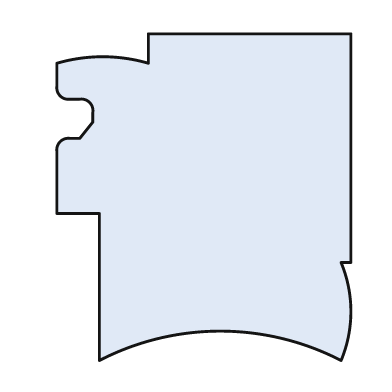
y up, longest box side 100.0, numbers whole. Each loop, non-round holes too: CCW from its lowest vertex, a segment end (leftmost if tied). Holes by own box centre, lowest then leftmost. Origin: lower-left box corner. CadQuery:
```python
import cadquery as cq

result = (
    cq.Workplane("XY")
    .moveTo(13.0, 0.0)
    .threePointArc((50.0, 9.0), (87.0, 0.0))
    .threePointArc((90.0, 15.0), (87.0, 30.0))
    .lineTo(90.0, 30.0)
    .lineTo(90.0, 100.0)
    .lineTo(28.0, 100.0)
    .lineTo(28.0, 91.0)
    .threePointArc((14.0, 93.0), (0.0, 91.0))
    .lineTo(0.0, 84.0)
    .threePointArc((1.0, 81.0), (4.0, 80.0))
    .lineTo(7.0, 80.0)
    .threePointArc((10.0, 79.0), (11.0, 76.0))
    .lineTo(11.0, 73.0)
    .lineTo(7.0, 68.0)
    .lineTo(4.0, 68.0)
    .threePointArc((1.0, 67.0), (0.0, 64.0))
    .lineTo(0.0, 45.0)
    .lineTo(13.0, 45.0)
    .close()
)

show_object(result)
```